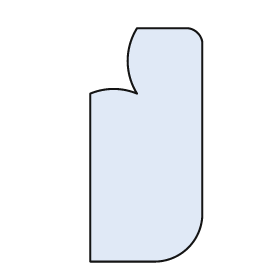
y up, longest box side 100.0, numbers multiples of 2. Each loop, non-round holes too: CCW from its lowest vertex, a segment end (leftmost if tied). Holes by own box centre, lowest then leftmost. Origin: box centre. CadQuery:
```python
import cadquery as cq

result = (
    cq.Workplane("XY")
    .moveTo(-24.0, -50.0)
    .lineTo(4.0, -50.0)
    .threePointArc((18.0, -44.0), (24.0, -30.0))
    .lineTo(24.0, 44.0)
    .threePointArc((22.0, 48.0), (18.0, 50.0))
    .lineTo(-4.0, 50.0)
    .threePointArc((-8.0, 36.0), (-4.0, 22.0))
    .threePointArc((-14.0, 24.0), (-24.0, 22.0))
    .close()
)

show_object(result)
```